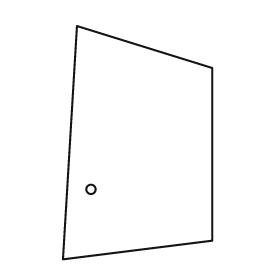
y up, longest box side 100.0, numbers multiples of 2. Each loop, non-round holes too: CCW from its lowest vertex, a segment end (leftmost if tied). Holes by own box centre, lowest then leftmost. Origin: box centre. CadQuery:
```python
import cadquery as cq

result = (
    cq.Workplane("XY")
    .moveTo(-32.0, -50.0)
    .lineTo(32.0, -42.0)
    .lineTo(32.0, 32.0)
    .lineTo(-26.0, 50.0)
    .close()
    .moveTo(-20.0, -20.0)
    .circle(2.0)
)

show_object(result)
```